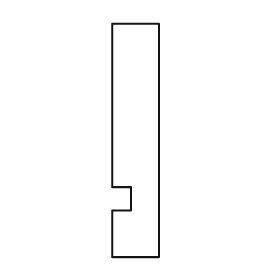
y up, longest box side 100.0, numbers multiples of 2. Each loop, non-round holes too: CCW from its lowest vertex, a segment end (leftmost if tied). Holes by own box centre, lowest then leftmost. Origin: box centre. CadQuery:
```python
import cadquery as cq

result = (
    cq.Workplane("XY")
    .moveTo(-10.0, -50.0)
    .lineTo(10.0, -50.0)
    .lineTo(10.0, 50.0)
    .lineTo(-10.0, 50.0)
    .lineTo(-10.0, -20.0)
    .lineTo(-2.0, -20.0)
    .lineTo(-2.0, -30.0)
    .lineTo(-10.0, -30.0)
    .close()
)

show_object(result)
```